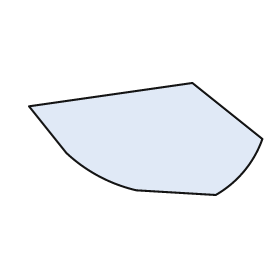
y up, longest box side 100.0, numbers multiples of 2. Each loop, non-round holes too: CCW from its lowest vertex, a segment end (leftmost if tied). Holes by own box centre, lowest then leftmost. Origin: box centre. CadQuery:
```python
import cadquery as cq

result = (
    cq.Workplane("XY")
    .moveTo(30.0, -24.0)
    .threePointArc((42.0, -14.0), (50.0, 0.0))
    .lineTo(20.0, 24.0)
    .lineTo(-50.0, 14.0)
    .lineTo(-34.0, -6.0)
    .threePointArc((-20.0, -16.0), (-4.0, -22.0))
    .close()
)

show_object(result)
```